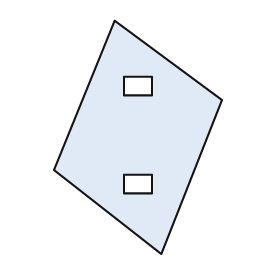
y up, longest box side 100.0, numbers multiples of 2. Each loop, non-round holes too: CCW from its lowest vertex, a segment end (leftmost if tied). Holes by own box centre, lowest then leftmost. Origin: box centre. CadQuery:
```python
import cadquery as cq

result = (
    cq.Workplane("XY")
    .moveTo(10.0, -50.0)
    .lineTo(36.0, 16.0)
    .lineTo(-10.0, 50.0)
    .lineTo(-36.0, -14.0)
    .close()
    .moveTo(-6.0, -24.0)
    .lineTo(6.0, -24.0)
    .lineTo(6.0, -16.0)
    .lineTo(-6.0, -16.0)
    .close()
    .moveTo(-6.0, 18.0)
    .lineTo(6.0, 18.0)
    .lineTo(6.0, 26.0)
    .lineTo(-6.0, 26.0)
    .close()
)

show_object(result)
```